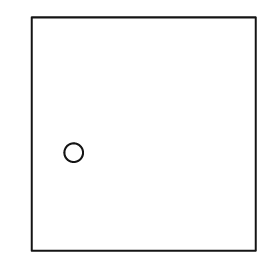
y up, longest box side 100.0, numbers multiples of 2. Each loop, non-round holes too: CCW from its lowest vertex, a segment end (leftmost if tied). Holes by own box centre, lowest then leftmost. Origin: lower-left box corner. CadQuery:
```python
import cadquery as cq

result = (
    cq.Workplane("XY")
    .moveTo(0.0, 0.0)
    .lineTo(96.0, 0.0)
    .lineTo(96.0, 100.0)
    .lineTo(0.0, 100.0)
    .close()
    .moveTo(18.0, 42.0)
    .circle(4.0)
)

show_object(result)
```